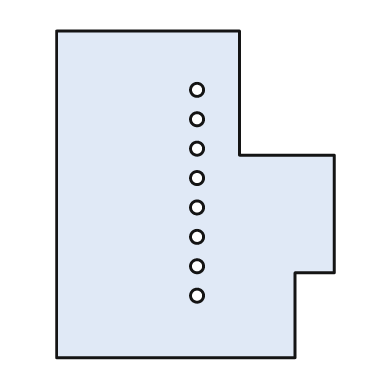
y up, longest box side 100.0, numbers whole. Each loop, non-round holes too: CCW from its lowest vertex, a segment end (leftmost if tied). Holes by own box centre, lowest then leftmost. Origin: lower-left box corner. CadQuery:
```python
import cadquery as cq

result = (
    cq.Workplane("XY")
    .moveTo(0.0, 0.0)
    .lineTo(73.0, 0.0)
    .lineTo(73.0, 26.0)
    .lineTo(85.0, 26.0)
    .lineTo(85.0, 62.0)
    .lineTo(56.0, 62.0)
    .lineTo(56.0, 100.0)
    .lineTo(0.0, 100.0)
    .close()
    .moveTo(43.0, 19.0)
    .circle(2.0)
    .moveTo(43.0, 28.0)
    .circle(2.0)
    .moveTo(43.0, 37.0)
    .circle(2.0)
    .moveTo(43.0, 46.0)
    .circle(2.0)
    .moveTo(43.0, 55.0)
    .circle(2.0)
    .moveTo(43.0, 64.0)
    .circle(2.0)
    .moveTo(43.0, 73.0)
    .circle(2.0)
    .moveTo(43.0, 82.0)
    .circle(2.0)
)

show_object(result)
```